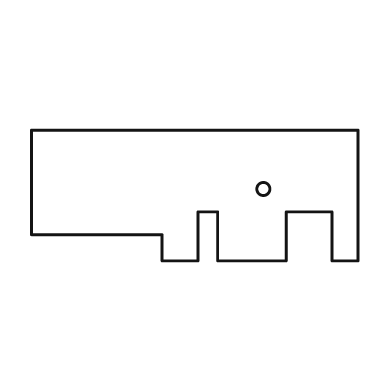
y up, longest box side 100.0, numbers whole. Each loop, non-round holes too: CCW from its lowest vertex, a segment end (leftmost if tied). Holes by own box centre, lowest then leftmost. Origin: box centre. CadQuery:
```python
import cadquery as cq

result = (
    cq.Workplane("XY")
    .moveTo(-10.0, -20.0)
    .lineTo(1.0, -20.0)
    .lineTo(1.0, -5.0)
    .lineTo(7.0, -5.0)
    .lineTo(7.0, -20.0)
    .lineTo(28.0, -20.0)
    .lineTo(28.0, -5.0)
    .lineTo(42.0, -5.0)
    .lineTo(42.0, -20.0)
    .lineTo(50.0, -20.0)
    .lineTo(50.0, 20.0)
    .lineTo(-50.0, 20.0)
    .lineTo(-50.0, -12.0)
    .lineTo(-10.0, -12.0)
    .close()
    .moveTo(21.0, 2.0)
    .circle(2.0)
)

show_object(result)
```